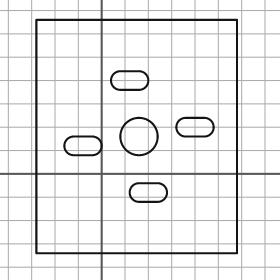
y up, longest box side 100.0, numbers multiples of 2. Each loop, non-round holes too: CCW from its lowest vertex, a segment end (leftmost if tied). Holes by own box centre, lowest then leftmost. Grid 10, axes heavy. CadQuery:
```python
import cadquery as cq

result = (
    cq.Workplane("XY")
    .moveTo(-28.0, -34.0)
    .lineTo(58.0, -34.0)
    .lineTo(58.0, 66.0)
    .lineTo(-28.0, 66.0)
    .close()
    .moveTo(16.0, -12.0)
    .lineTo(24.0, -12.0)
    .threePointArc((28.0, -8.0), (24.0, -4.0))
    .lineTo(16.0, -4.0)
    .threePointArc((12.0, -8.0), (16.0, -12.0))
    .close()
    .moveTo(-12.0, 8.0)
    .lineTo(-4.0, 8.0)
    .threePointArc((0.0, 12.0), (-4.0, 16.0))
    .lineTo(-12.0, 16.0)
    .threePointArc((-16.0, 12.0), (-12.0, 8.0))
    .close()
    .moveTo(16.0, 16.0)
    .circle(8.0)
    .moveTo(36.0, 16.0)
    .lineTo(44.0, 16.0)
    .threePointArc((48.0, 20.0), (44.0, 24.0))
    .lineTo(36.0, 24.0)
    .threePointArc((32.0, 20.0), (36.0, 16.0))
    .close()
    .moveTo(8.0, 36.0)
    .lineTo(16.0, 36.0)
    .threePointArc((20.0, 40.0), (16.0, 44.0))
    .lineTo(8.0, 44.0)
    .threePointArc((4.0, 40.0), (8.0, 36.0))
    .close()
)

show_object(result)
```